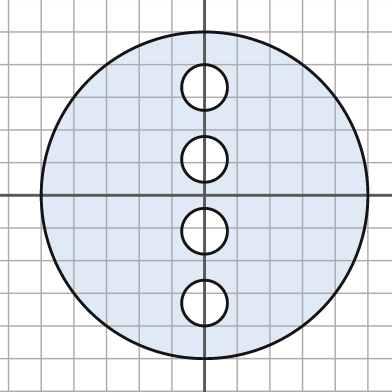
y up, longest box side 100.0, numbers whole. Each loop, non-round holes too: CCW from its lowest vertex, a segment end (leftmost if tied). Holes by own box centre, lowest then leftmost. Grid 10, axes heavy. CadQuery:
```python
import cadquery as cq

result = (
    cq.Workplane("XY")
    .moveTo(0.0, 0.0)
    .circle(50.0)
    .moveTo(0.0, -33.0)
    .circle(7.0)
    .moveTo(0.0, -11.0)
    .circle(7.0)
    .moveTo(0.0, 11.0)
    .circle(7.0)
    .moveTo(0.0, 33.0)
    .circle(7.0)
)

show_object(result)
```